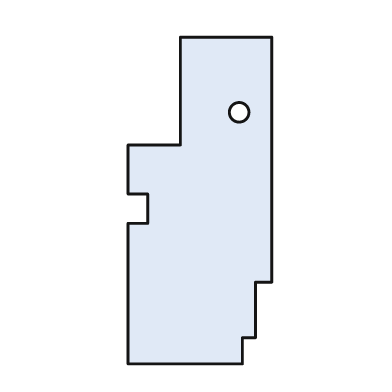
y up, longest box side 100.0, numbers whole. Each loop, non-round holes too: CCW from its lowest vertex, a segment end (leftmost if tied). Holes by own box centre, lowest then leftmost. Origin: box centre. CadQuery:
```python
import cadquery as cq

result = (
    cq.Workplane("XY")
    .moveTo(-22.0, -50.0)
    .lineTo(13.0, -50.0)
    .lineTo(13.0, -42.0)
    .lineTo(17.0, -42.0)
    .lineTo(17.0, -25.0)
    .lineTo(22.0, -25.0)
    .lineTo(22.0, 50.0)
    .lineTo(-6.0, 50.0)
    .lineTo(-6.0, 17.0)
    .lineTo(-22.0, 17.0)
    .lineTo(-22.0, 2.0)
    .lineTo(-16.0, 2.0)
    .lineTo(-16.0, -7.0)
    .lineTo(-22.0, -7.0)
    .close()
    .moveTo(12.0, 27.0)
    .circle(3.0)
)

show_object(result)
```